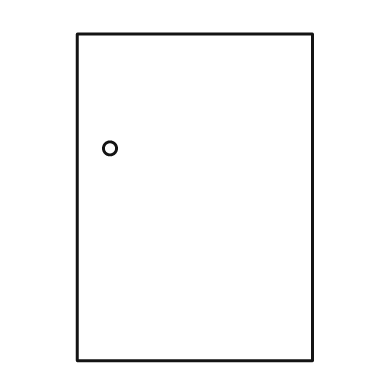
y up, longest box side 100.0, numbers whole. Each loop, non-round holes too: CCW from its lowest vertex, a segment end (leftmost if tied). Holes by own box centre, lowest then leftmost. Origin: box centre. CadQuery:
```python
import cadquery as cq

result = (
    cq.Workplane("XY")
    .moveTo(-36.0, -50.0)
    .lineTo(36.0, -50.0)
    .lineTo(36.0, 50.0)
    .lineTo(-36.0, 50.0)
    .close()
    .moveTo(-26.0, 15.0)
    .circle(2.0)
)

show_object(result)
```